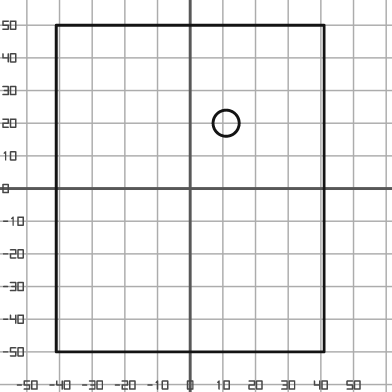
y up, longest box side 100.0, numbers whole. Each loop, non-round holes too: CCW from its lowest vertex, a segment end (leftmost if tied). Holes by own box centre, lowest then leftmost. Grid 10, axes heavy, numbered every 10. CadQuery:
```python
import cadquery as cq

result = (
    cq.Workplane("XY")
    .moveTo(-41.0, -50.0)
    .lineTo(41.0, -50.0)
    .lineTo(41.0, 50.0)
    .lineTo(-41.0, 50.0)
    .close()
    .moveTo(11.0, 20.0)
    .circle(4.0)
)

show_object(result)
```